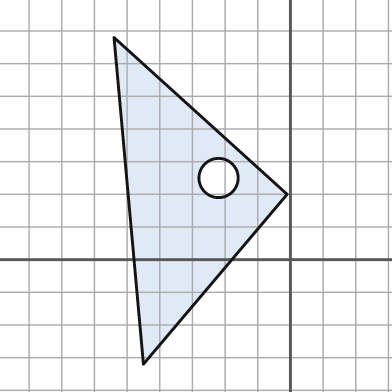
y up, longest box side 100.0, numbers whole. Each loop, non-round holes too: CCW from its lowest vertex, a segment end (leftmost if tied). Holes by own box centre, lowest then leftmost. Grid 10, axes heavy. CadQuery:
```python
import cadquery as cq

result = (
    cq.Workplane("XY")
    .moveTo(-45.0, -32.0)
    .lineTo(-1.0, 20.0)
    .lineTo(-54.0, 68.0)
    .close()
    .moveTo(-22.0, 25.0)
    .circle(6.0)
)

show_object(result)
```